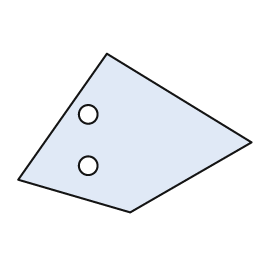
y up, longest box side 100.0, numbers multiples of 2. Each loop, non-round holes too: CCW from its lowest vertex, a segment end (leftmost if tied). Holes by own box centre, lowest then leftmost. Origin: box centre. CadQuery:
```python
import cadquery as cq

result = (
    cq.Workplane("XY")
    .moveTo(-2.0, -34.0)
    .lineTo(50.0, -4.0)
    .lineTo(-12.0, 34.0)
    .lineTo(-50.0, -20.0)
    .close()
    .moveTo(-20.0, -14.0)
    .circle(4.0)
    .moveTo(-20.0, 8.0)
    .circle(4.0)
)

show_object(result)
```